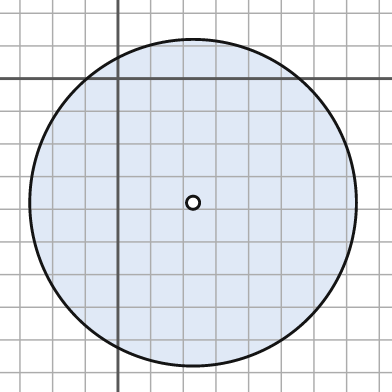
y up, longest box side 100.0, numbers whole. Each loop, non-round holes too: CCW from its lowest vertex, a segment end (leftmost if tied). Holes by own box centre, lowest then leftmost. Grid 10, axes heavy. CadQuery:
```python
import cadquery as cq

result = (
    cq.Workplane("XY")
    .moveTo(23.0, -38.0)
    .circle(50.0)
    .moveTo(23.0, -38.0)
    .circle(2.0)
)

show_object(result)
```